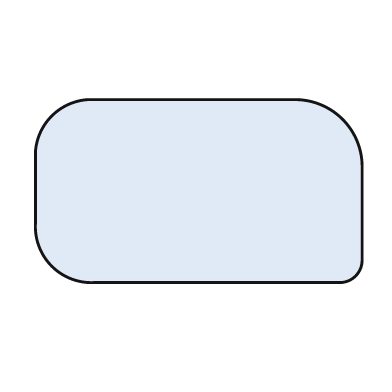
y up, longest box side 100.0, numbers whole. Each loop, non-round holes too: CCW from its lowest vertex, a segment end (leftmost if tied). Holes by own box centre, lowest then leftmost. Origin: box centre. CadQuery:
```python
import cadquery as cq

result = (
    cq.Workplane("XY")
    .moveTo(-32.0, -28.0)
    .lineTo(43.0, -28.0)
    .threePointArc((48.0, -26.0), (50.0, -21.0))
    .lineTo(50.0, 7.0)
    .threePointArc((44.0, 22.0), (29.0, 28.0))
    .lineTo(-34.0, 28.0)
    .threePointArc((-45.0, 23.0), (-50.0, 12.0))
    .lineTo(-50.0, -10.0)
    .threePointArc((-45.0, -23.0), (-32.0, -28.0))
    .close()
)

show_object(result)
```